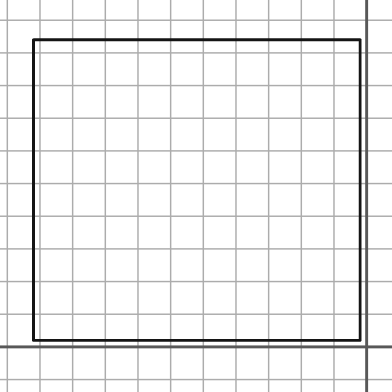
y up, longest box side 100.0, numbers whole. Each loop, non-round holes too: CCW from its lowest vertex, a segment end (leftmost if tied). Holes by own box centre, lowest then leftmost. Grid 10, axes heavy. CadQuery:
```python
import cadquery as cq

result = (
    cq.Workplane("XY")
    .moveTo(-102.0, 2.0)
    .lineTo(-2.0, 2.0)
    .lineTo(-2.0, 94.0)
    .lineTo(-102.0, 94.0)
    .close()
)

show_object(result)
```